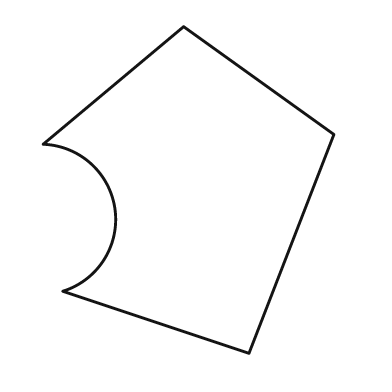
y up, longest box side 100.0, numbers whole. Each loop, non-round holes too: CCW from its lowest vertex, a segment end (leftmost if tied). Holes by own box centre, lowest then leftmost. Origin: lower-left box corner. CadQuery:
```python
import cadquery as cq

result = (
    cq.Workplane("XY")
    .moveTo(63.0, 0.0)
    .lineTo(89.0, 67.0)
    .lineTo(43.0, 100.0)
    .lineTo(0.0, 64.0)
    .threePointArc((22.0, 44.0), (6.0, 19.0))
    .close()
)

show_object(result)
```